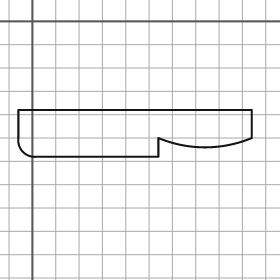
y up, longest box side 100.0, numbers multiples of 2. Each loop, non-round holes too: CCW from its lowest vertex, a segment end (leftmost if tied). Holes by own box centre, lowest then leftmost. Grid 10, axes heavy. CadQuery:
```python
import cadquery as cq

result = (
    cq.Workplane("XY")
    .moveTo(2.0, -58.0)
    .lineTo(54.0, -58.0)
    .lineTo(54.0, -50.0)
    .threePointArc((74.0, -54.0), (94.0, -50.0))
    .lineTo(94.0, -38.0)
    .lineTo(-6.0, -38.0)
    .lineTo(-6.0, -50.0)
    .threePointArc((-4.0, -56.0), (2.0, -58.0))
    .close()
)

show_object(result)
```